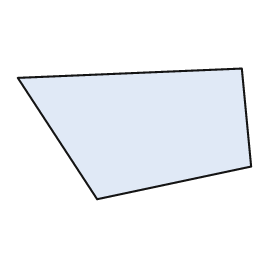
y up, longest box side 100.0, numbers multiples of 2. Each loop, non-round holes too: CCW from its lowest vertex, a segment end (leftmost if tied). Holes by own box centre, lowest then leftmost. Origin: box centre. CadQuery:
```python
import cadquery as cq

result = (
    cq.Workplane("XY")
    .moveTo(-16.0, -28.0)
    .lineTo(50.0, -14.0)
    .lineTo(46.0, 28.0)
    .lineTo(-50.0, 24.0)
    .close()
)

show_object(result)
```